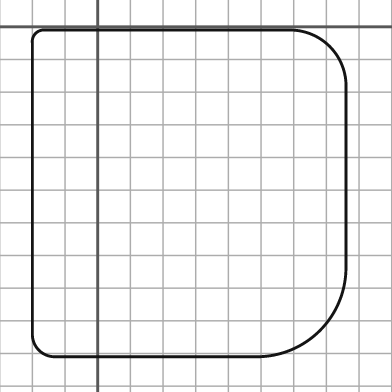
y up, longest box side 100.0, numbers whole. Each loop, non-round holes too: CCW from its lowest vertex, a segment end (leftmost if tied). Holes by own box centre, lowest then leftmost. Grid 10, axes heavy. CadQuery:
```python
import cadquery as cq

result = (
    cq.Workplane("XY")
    .moveTo(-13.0, -101.0)
    .lineTo(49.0, -101.0)
    .threePointArc((68.0, -93.0), (76.0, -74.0))
    .lineTo(76.0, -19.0)
    .threePointArc((71.0, -6.0), (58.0, -1.0))
    .lineTo(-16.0, -1.0)
    .threePointArc((-19.0, -2.0), (-20.0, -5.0))
    .lineTo(-20.0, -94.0)
    .threePointArc((-18.0, -99.0), (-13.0, -101.0))
    .close()
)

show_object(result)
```